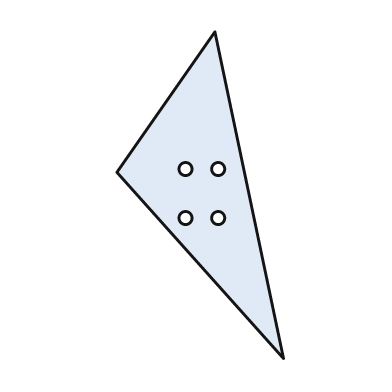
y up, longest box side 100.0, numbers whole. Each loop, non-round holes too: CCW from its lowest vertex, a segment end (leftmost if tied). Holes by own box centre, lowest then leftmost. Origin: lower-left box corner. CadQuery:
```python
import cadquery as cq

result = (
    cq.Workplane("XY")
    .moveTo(51.0, 0.0)
    .lineTo(30.0, 100.0)
    .lineTo(0.0, 57.0)
    .close()
    .moveTo(21.0, 43.0)
    .circle(2.0)
    .moveTo(31.0, 43.0)
    .circle(2.0)
    .moveTo(21.0, 58.0)
    .circle(2.0)
    .moveTo(31.0, 58.0)
    .circle(2.0)
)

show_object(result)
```